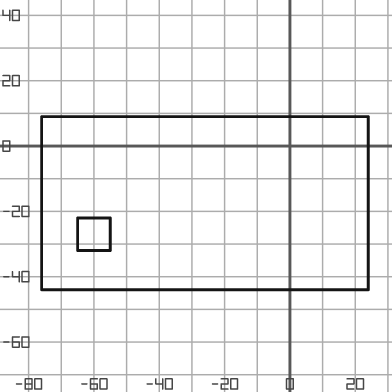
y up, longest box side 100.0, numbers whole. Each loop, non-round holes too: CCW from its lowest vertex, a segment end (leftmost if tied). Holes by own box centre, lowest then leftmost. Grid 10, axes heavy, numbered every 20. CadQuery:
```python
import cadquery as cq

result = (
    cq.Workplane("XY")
    .moveTo(-76.0, -44.0)
    .lineTo(24.0, -44.0)
    .lineTo(24.0, 9.0)
    .lineTo(-76.0, 9.0)
    .close()
    .moveTo(-65.0, -32.0)
    .lineTo(-55.0, -32.0)
    .lineTo(-55.0, -22.0)
    .lineTo(-65.0, -22.0)
    .close()
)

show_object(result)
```